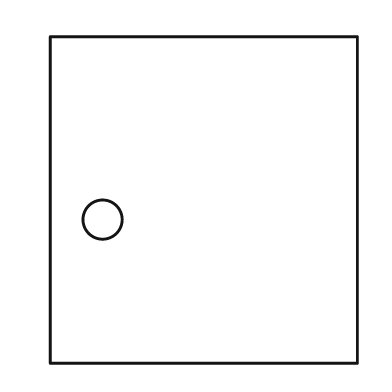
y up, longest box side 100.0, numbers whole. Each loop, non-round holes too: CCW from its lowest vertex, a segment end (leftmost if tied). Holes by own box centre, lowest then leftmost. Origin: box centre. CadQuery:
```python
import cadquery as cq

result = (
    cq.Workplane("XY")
    .moveTo(-47.0, -50.0)
    .lineTo(47.0, -50.0)
    .lineTo(47.0, 50.0)
    .lineTo(-47.0, 50.0)
    .close()
    .moveTo(-31.0, -6.0)
    .circle(6.0)
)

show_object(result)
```